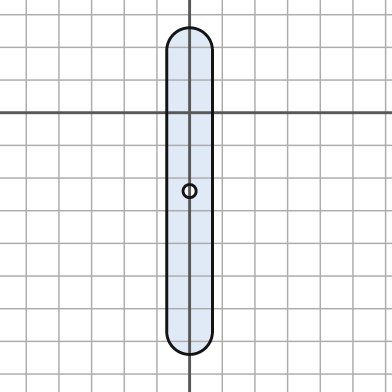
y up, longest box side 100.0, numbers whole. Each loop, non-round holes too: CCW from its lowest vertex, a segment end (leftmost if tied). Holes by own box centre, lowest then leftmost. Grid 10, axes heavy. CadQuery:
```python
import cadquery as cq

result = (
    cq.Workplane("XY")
    .moveTo(-7.0, -67.0)
    .threePointArc((0.0, -74.0), (7.0, -67.0))
    .lineTo(7.0, 19.0)
    .threePointArc((0.0, 26.0), (-7.0, 19.0))
    .close()
    .moveTo(0.0, -24.0)
    .circle(2.0)
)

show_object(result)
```